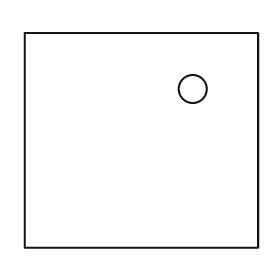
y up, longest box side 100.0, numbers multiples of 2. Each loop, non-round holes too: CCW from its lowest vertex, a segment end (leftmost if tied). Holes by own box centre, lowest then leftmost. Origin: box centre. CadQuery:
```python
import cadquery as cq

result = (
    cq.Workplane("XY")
    .moveTo(-50.0, -46.0)
    .lineTo(50.0, -46.0)
    .lineTo(50.0, 46.0)
    .lineTo(-50.0, 46.0)
    .close()
    .moveTo(22.0, 22.0)
    .circle(6.0)
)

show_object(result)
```